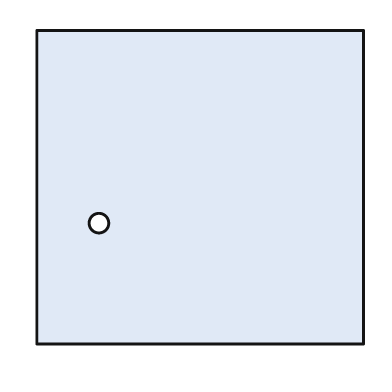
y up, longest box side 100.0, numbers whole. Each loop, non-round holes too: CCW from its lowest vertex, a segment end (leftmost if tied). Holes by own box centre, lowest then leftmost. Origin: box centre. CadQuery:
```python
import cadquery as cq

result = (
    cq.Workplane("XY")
    .moveTo(-50.0, -48.0)
    .lineTo(50.0, -48.0)
    .lineTo(50.0, 48.0)
    .lineTo(-50.0, 48.0)
    .close()
    .moveTo(-31.0, -11.0)
    .circle(3.0)
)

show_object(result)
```